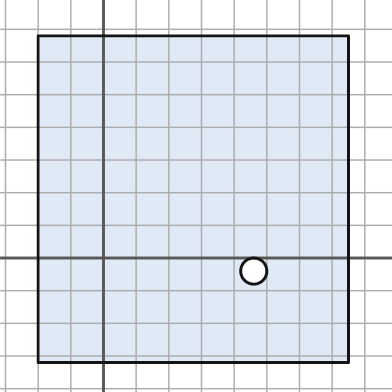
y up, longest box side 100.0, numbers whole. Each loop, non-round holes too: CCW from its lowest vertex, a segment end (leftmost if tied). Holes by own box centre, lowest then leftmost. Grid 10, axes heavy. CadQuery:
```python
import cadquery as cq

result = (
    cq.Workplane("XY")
    .moveTo(-20.0, -32.0)
    .lineTo(75.0, -32.0)
    .lineTo(75.0, 68.0)
    .lineTo(-20.0, 68.0)
    .close()
    .moveTo(46.0, -4.0)
    .circle(4.0)
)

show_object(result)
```